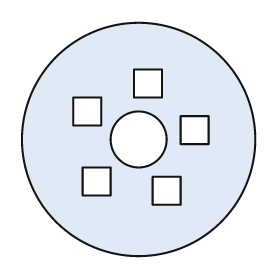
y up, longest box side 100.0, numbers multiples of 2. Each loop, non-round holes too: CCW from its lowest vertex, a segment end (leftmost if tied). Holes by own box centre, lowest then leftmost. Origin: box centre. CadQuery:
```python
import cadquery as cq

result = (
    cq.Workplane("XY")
    .moveTo(0.0, 0.0)
    .circle(50.0)
    .moveTo(6.0, -28.0)
    .lineTo(18.0, -28.0)
    .lineTo(18.0, -16.0)
    .lineTo(6.0, -16.0)
    .close()
    .moveTo(-24.0, -24.0)
    .lineTo(-12.0, -24.0)
    .lineTo(-12.0, -12.0)
    .lineTo(-24.0, -12.0)
    .close()
    .moveTo(0.0, 0.0)
    .circle(12.0)
    .moveTo(18.0, -2.0)
    .lineTo(30.0, -2.0)
    .lineTo(30.0, 10.0)
    .lineTo(18.0, 10.0)
    .close()
    .moveTo(-28.0, 6.0)
    .lineTo(-16.0, 6.0)
    .lineTo(-16.0, 18.0)
    .lineTo(-28.0, 18.0)
    .close()
    .moveTo(-2.0, 18.0)
    .lineTo(10.0, 18.0)
    .lineTo(10.0, 30.0)
    .lineTo(-2.0, 30.0)
    .close()
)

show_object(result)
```